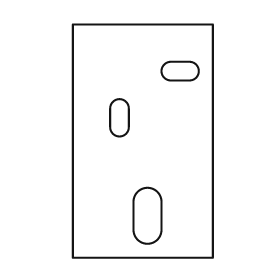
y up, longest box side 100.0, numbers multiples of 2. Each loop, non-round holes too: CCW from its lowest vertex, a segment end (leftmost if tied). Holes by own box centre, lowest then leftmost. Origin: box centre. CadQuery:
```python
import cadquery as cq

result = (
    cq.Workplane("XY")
    .moveTo(-30.0, -50.0)
    .lineTo(30.0, -50.0)
    .lineTo(30.0, 50.0)
    .lineTo(-30.0, 50.0)
    .close()
    .moveTo(-4.0, -38.0)
    .threePointArc((2.0, -44.0), (8.0, -38.0))
    .lineTo(8.0, -26.0)
    .threePointArc((2.0, -20.0), (-4.0, -26.0))
    .close()
    .moveTo(-14.0, 6.0)
    .threePointArc((-10.0, 2.0), (-6.0, 6.0))
    .lineTo(-6.0, 14.0)
    .threePointArc((-10.0, 18.0), (-14.0, 14.0))
    .close()
    .moveTo(12.0, 26.0)
    .lineTo(20.0, 26.0)
    .threePointArc((24.0, 30.0), (20.0, 34.0))
    .lineTo(12.0, 34.0)
    .threePointArc((8.0, 30.0), (12.0, 26.0))
    .close()
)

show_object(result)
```